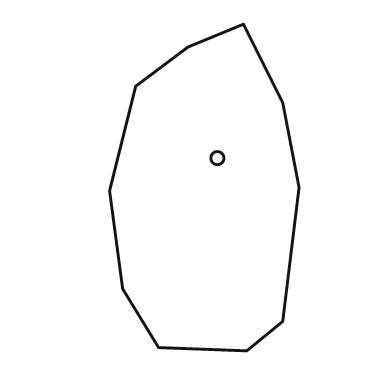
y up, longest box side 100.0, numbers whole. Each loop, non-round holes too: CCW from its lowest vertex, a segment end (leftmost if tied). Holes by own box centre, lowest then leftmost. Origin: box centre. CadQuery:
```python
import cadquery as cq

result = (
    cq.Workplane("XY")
    .moveTo(13.0, -50.0)
    .lineTo(24.0, -41.0)
    .lineTo(29.0, 0.0)
    .lineTo(24.0, 26.0)
    .lineTo(12.0, 50.0)
    .lineTo(-5.0, 43.0)
    .lineTo(-21.0, 31.0)
    .lineTo(-29.0, -1.0)
    .lineTo(-25.0, -31.0)
    .lineTo(-14.0, -49.0)
    .close()
    .moveTo(4.0, 9.0)
    .circle(2.0)
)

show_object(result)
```